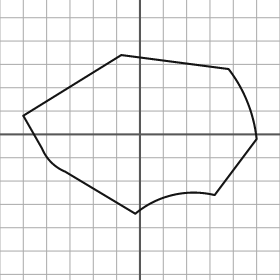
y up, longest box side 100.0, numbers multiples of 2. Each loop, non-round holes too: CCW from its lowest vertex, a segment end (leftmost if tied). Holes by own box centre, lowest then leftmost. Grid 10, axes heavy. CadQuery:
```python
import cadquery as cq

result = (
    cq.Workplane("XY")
    .moveTo(-2.0, -34.0)
    .threePointArc((14.0, -26.0), (32.0, -26.0))
    .lineTo(50.0, -2.0)
    .threePointArc((46.0, 14.0), (38.0, 28.0))
    .lineTo(-8.0, 34.0)
    .lineTo(-50.0, 8.0)
    .lineTo(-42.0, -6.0)
    .threePointArc((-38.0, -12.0), (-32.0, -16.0))
    .close()
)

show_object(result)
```